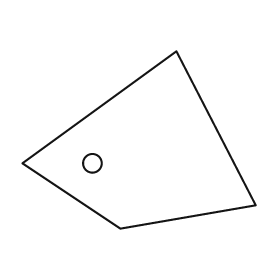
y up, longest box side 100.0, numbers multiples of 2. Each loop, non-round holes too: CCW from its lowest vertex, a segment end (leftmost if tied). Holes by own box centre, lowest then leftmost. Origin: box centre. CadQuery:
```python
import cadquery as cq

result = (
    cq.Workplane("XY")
    .moveTo(-8.0, -38.0)
    .lineTo(50.0, -28.0)
    .lineTo(16.0, 38.0)
    .lineTo(-50.0, -10.0)
    .close()
    .moveTo(-20.0, -10.0)
    .circle(4.0)
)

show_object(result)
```